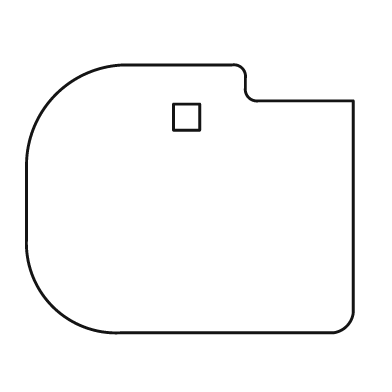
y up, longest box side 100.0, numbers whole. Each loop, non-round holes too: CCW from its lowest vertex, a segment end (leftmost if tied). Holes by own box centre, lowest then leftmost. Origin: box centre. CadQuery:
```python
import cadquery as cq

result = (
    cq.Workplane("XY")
    .moveTo(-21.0, -41.0)
    .lineTo(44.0, -41.0)
    .threePointArc((48.0, -39.0), (50.0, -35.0))
    .lineTo(50.0, 30.0)
    .lineTo(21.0, 30.0)
    .threePointArc((18.0, 31.0), (17.0, 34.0))
    .lineTo(17.0, 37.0)
    .threePointArc((16.0, 40.0), (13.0, 41.0))
    .lineTo(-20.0, 41.0)
    .threePointArc((-41.0, 32.0), (-50.0, 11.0))
    .lineTo(-50.0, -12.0)
    .threePointArc((-42.0, -33.0), (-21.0, -41.0))
    .close()
    .moveTo(-5.0, 21.0)
    .lineTo(3.0, 21.0)
    .lineTo(3.0, 29.0)
    .lineTo(-5.0, 29.0)
    .close()
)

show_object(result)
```